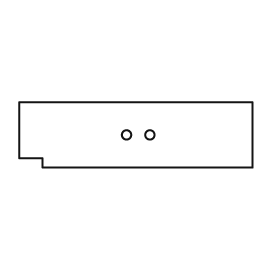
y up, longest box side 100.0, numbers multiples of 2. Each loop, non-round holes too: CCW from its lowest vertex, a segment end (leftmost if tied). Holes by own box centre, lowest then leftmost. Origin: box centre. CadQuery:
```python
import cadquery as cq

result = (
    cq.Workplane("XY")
    .moveTo(-40.0, -14.0)
    .lineTo(50.0, -14.0)
    .lineTo(50.0, 14.0)
    .lineTo(-50.0, 14.0)
    .lineTo(-50.0, -10.0)
    .lineTo(-40.0, -10.0)
    .close()
    .moveTo(-4.0, 0.0)
    .circle(2.0)
    .moveTo(6.0, 0.0)
    .circle(2.0)
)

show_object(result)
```